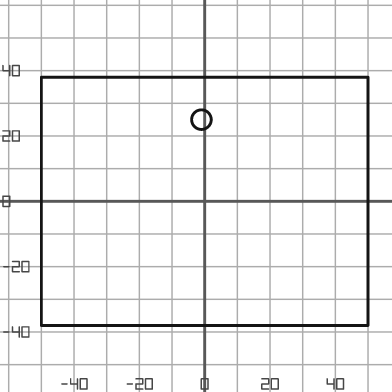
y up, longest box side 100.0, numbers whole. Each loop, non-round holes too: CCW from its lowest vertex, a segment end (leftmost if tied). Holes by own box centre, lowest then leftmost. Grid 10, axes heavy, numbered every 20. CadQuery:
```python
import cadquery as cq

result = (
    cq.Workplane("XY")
    .moveTo(-50.0, -38.0)
    .lineTo(50.0, -38.0)
    .lineTo(50.0, 38.0)
    .lineTo(-50.0, 38.0)
    .close()
    .moveTo(-1.0, 25.0)
    .circle(3.0)
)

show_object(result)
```